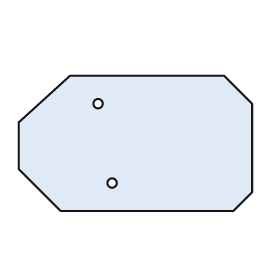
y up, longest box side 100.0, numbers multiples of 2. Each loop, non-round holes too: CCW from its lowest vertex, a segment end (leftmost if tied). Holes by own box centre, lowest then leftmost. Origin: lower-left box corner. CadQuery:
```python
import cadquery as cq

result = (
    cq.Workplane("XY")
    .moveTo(18.0, 0.0)
    .lineTo(92.0, 0.0)
    .lineTo(100.0, 8.0)
    .lineTo(100.0, 46.0)
    .lineTo(88.0, 58.0)
    .lineTo(22.0, 58.0)
    .lineTo(0.0, 38.0)
    .lineTo(0.0, 18.0)
    .close()
    .moveTo(40.0, 12.0)
    .circle(2.0)
    .moveTo(34.0, 46.0)
    .circle(2.0)
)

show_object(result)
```